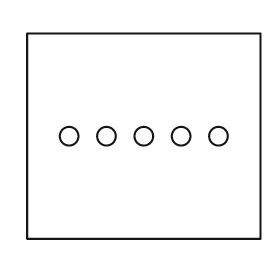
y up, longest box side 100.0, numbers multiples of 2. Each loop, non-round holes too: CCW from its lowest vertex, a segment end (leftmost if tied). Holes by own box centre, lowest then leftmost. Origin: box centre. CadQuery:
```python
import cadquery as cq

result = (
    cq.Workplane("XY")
    .moveTo(-50.0, -44.0)
    .lineTo(50.0, -44.0)
    .lineTo(50.0, 44.0)
    .lineTo(-50.0, 44.0)
    .close()
    .moveTo(-32.0, 0.0)
    .circle(4.0)
    .moveTo(-16.0, 0.0)
    .circle(4.0)
    .moveTo(0.0, 0.0)
    .circle(4.0)
    .moveTo(16.0, 0.0)
    .circle(4.0)
    .moveTo(32.0, 0.0)
    .circle(4.0)
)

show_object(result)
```